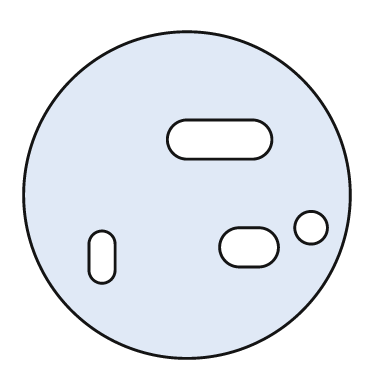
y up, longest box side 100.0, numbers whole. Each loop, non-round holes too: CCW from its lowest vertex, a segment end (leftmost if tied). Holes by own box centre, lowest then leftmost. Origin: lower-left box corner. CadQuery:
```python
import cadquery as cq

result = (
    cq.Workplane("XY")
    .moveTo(50.0, 50.0)
    .circle(50.0)
    .moveTo(20.0, 27.0)
    .threePointArc((24.0, 23.0), (28.0, 27.0))
    .lineTo(28.0, 35.0)
    .threePointArc((24.0, 39.0), (20.0, 35.0))
    .close()
    .moveTo(66.0, 28.0)
    .lineTo(72.0, 28.0)
    .threePointArc((78.0, 34.0), (72.0, 40.0))
    .lineTo(66.0, 40.0)
    .threePointArc((60.0, 34.0), (66.0, 28.0))
    .close()
    .moveTo(88.0, 40.0)
    .circle(5.0)
    .moveTo(50.0, 61.0)
    .lineTo(70.0, 61.0)
    .threePointArc((76.0, 67.0), (70.0, 73.0))
    .lineTo(50.0, 73.0)
    .threePointArc((44.0, 67.0), (50.0, 61.0))
    .close()
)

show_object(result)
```